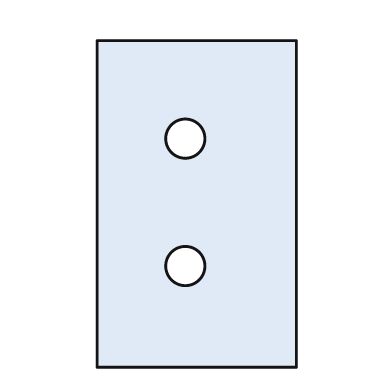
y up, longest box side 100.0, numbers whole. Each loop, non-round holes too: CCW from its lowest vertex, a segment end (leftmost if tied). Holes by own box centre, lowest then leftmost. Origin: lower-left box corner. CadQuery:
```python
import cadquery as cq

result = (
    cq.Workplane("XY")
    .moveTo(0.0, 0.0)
    .lineTo(61.0, 0.0)
    .lineTo(61.0, 100.0)
    .lineTo(0.0, 100.0)
    .close()
    .moveTo(27.0, 31.0)
    .circle(6.0)
    .moveTo(27.0, 70.0)
    .circle(6.0)
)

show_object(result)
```